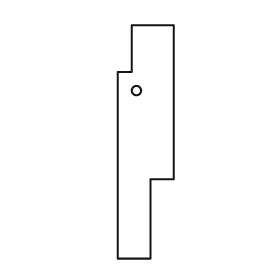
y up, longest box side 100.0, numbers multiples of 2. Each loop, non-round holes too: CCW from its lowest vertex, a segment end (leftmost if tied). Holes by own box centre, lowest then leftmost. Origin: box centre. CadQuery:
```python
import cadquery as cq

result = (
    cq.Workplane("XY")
    .moveTo(-12.0, -50.0)
    .lineTo(2.0, -50.0)
    .lineTo(2.0, -16.0)
    .lineTo(12.0, -16.0)
    .lineTo(12.0, 50.0)
    .lineTo(-6.0, 50.0)
    .lineTo(-6.0, 30.0)
    .lineTo(-12.0, 30.0)
    .close()
    .moveTo(-4.0, 22.0)
    .circle(2.0)
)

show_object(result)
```